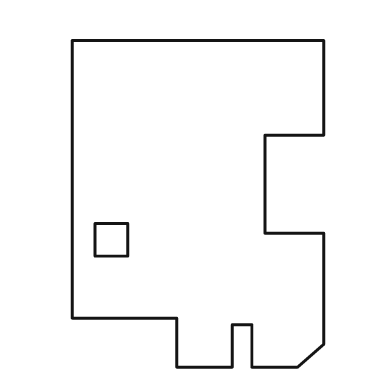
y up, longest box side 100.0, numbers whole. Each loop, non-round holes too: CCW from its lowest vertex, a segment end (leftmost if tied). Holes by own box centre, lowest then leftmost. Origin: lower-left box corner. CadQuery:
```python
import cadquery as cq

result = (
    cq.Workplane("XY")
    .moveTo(32.0, 0.0)
    .lineTo(49.0, 0.0)
    .lineTo(49.0, 13.0)
    .lineTo(55.0, 13.0)
    .lineTo(55.0, 0.0)
    .lineTo(69.0, 0.0)
    .lineTo(77.0, 7.0)
    .lineTo(77.0, 41.0)
    .lineTo(59.0, 41.0)
    .lineTo(59.0, 71.0)
    .lineTo(77.0, 71.0)
    .lineTo(77.0, 100.0)
    .lineTo(0.0, 100.0)
    .lineTo(0.0, 15.0)
    .lineTo(32.0, 15.0)
    .close()
    .moveTo(7.0, 34.0)
    .lineTo(17.0, 34.0)
    .lineTo(17.0, 44.0)
    .lineTo(7.0, 44.0)
    .close()
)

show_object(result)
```